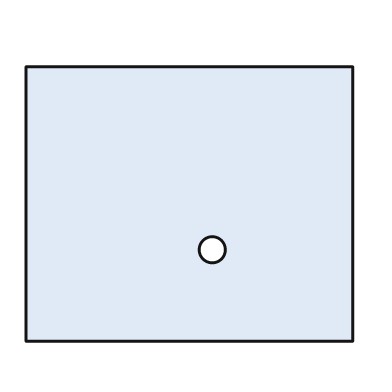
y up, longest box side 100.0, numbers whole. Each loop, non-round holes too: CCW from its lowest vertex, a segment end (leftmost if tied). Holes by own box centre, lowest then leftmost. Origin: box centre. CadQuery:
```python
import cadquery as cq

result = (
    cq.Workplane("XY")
    .moveTo(-50.0, -42.0)
    .lineTo(50.0, -42.0)
    .lineTo(50.0, 42.0)
    .lineTo(-50.0, 42.0)
    .close()
    .moveTo(7.0, -14.0)
    .circle(4.0)
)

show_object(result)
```